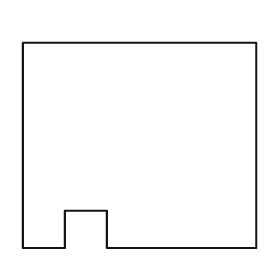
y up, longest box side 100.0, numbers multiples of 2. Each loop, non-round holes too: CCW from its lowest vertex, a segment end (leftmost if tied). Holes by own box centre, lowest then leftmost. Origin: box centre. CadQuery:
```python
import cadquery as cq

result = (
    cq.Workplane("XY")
    .moveTo(-50.0, -44.0)
    .lineTo(-32.0, -44.0)
    .lineTo(-32.0, -28.0)
    .lineTo(-14.0, -28.0)
    .lineTo(-14.0, -44.0)
    .lineTo(50.0, -44.0)
    .lineTo(50.0, 44.0)
    .lineTo(-50.0, 44.0)
    .close()
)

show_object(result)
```